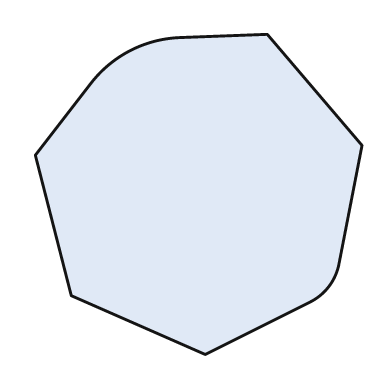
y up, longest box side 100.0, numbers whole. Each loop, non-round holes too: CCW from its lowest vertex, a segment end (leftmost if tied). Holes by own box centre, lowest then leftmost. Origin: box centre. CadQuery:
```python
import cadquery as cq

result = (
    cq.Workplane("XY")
    .moveTo(2.0, -49.0)
    .lineTo(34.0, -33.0)
    .threePointArc((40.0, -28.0), (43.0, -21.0))
    .lineTo(50.0, 15.0)
    .lineTo(21.0, 49.0)
    .lineTo(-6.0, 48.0)
    .threePointArc((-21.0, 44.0), (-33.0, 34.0))
    .lineTo(-50.0, 12.0)
    .lineTo(-39.0, -31.0)
    .close()
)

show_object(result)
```